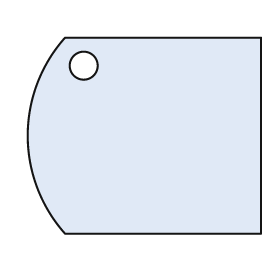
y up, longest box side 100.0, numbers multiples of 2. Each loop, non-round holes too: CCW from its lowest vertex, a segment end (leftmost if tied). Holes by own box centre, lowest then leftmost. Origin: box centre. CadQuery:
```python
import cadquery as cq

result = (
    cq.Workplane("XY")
    .moveTo(-34.0, -42.0)
    .lineTo(50.0, -42.0)
    .lineTo(50.0, 42.0)
    .lineTo(-34.0, 42.0)
    .threePointArc((-50.0, 0.0), (-34.0, -42.0))
    .close()
    .moveTo(-26.0, 30.0)
    .circle(6.0)
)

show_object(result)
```